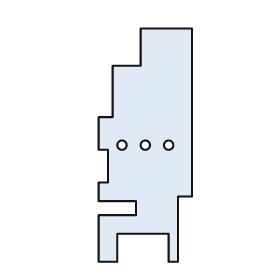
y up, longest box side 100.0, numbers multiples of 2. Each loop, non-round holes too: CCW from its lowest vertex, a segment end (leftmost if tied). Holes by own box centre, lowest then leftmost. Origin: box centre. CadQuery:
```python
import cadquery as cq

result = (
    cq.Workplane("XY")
    .moveTo(-20.0, -50.0)
    .lineTo(-12.0, -50.0)
    .lineTo(-12.0, -38.0)
    .lineTo(10.0, -38.0)
    .lineTo(10.0, -50.0)
    .lineTo(14.0, -50.0)
    .lineTo(14.0, -22.0)
    .lineTo(20.0, -22.0)
    .lineTo(20.0, 50.0)
    .lineTo(-2.0, 50.0)
    .lineTo(-2.0, 34.0)
    .lineTo(-14.0, 34.0)
    .lineTo(-14.0, 12.0)
    .lineTo(-20.0, 12.0)
    .lineTo(-20.0, -2.0)
    .lineTo(-16.0, -2.0)
    .lineTo(-16.0, -16.0)
    .lineTo(-20.0, -16.0)
    .lineTo(-20.0, -24.0)
    .lineTo(-4.0, -24.0)
    .lineTo(-4.0, -30.0)
    .lineTo(-20.0, -30.0)
    .close()
    .moveTo(-10.0, 0.0)
    .circle(2.0)
    .moveTo(0.0, 0.0)
    .circle(2.0)
    .moveTo(10.0, 0.0)
    .circle(2.0)
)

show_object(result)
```